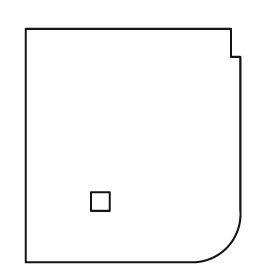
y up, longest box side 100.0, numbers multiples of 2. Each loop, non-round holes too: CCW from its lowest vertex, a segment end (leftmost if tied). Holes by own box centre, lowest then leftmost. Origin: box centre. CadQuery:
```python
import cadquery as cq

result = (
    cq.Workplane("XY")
    .moveTo(-46.0, -50.0)
    .lineTo(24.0, -50.0)
    .threePointArc((40.0, -44.0), (46.0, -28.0))
    .lineTo(46.0, 38.0)
    .lineTo(42.0, 38.0)
    .lineTo(42.0, 50.0)
    .lineTo(-46.0, 50.0)
    .close()
    .moveTo(-18.0, -28.0)
    .lineTo(-10.0, -28.0)
    .lineTo(-10.0, -20.0)
    .lineTo(-18.0, -20.0)
    .close()
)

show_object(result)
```